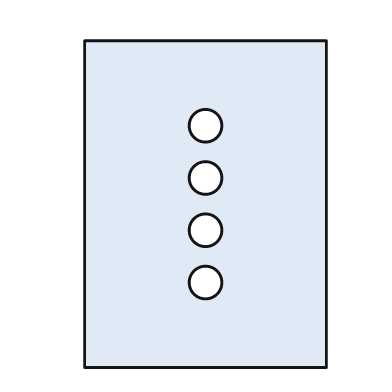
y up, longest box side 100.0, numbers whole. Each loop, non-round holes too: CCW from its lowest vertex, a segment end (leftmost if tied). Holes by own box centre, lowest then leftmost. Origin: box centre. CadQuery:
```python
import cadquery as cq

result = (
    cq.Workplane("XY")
    .moveTo(-37.0, -50.0)
    .lineTo(37.0, -50.0)
    .lineTo(37.0, 50.0)
    .lineTo(-37.0, 50.0)
    .close()
    .moveTo(0.0, -24.0)
    .circle(5.0)
    .moveTo(0.0, -8.0)
    .circle(5.0)
    .moveTo(0.0, 8.0)
    .circle(5.0)
    .moveTo(0.0, 24.0)
    .circle(5.0)
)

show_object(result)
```